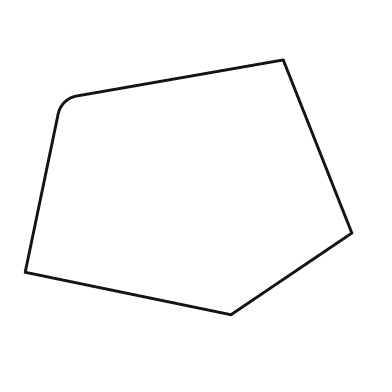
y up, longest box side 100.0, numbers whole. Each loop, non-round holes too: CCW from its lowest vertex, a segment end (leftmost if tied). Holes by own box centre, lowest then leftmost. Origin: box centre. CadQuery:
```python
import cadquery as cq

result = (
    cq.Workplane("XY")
    .moveTo(13.0, -39.0)
    .lineTo(50.0, -14.0)
    .lineTo(29.0, 39.0)
    .lineTo(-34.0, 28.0)
    .threePointArc((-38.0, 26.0), (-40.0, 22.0))
    .lineTo(-50.0, -26.0)
    .close()
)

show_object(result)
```